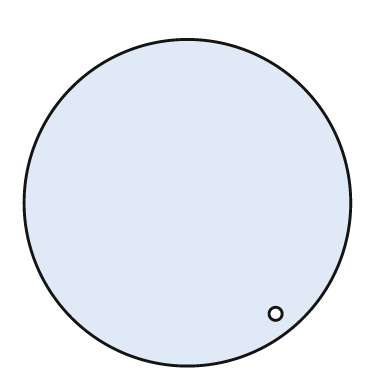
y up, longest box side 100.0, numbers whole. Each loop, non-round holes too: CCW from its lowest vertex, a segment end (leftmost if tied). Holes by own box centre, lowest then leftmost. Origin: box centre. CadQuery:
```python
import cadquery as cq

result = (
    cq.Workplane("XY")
    .moveTo(0.0, 0.0)
    .circle(50.0)
    .moveTo(27.0, -34.0)
    .circle(2.0)
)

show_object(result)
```